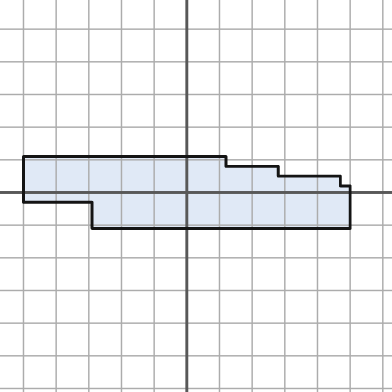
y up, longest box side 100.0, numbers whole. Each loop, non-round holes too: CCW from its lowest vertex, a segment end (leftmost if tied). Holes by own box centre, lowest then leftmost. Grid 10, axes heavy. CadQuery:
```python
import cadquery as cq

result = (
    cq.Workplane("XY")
    .moveTo(-29.0, -11.0)
    .lineTo(50.0, -11.0)
    .lineTo(50.0, 2.0)
    .lineTo(47.0, 2.0)
    .lineTo(47.0, 5.0)
    .lineTo(28.0, 5.0)
    .lineTo(28.0, 8.0)
    .lineTo(12.0, 8.0)
    .lineTo(12.0, 11.0)
    .lineTo(-50.0, 11.0)
    .lineTo(-50.0, -3.0)
    .lineTo(-29.0, -3.0)
    .close()
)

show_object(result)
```